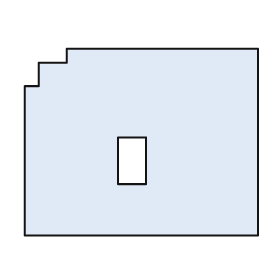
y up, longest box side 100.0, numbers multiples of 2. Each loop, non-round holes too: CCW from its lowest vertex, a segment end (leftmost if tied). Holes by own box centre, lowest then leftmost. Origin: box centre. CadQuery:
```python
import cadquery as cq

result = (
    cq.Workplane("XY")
    .moveTo(-50.0, -40.0)
    .lineTo(50.0, -40.0)
    .lineTo(50.0, 40.0)
    .lineTo(-32.0, 40.0)
    .lineTo(-32.0, 34.0)
    .lineTo(-44.0, 34.0)
    .lineTo(-44.0, 24.0)
    .lineTo(-50.0, 24.0)
    .close()
    .moveTo(-10.0, -18.0)
    .lineTo(2.0, -18.0)
    .lineTo(2.0, 2.0)
    .lineTo(-10.0, 2.0)
    .close()
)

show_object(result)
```